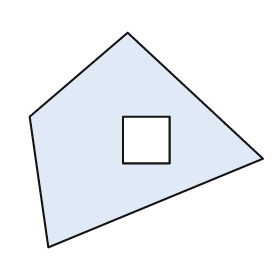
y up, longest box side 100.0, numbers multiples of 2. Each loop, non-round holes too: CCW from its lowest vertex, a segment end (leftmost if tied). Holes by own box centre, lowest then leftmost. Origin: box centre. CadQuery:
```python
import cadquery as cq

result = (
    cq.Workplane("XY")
    .moveTo(-42.0, -46.0)
    .lineTo(50.0, -8.0)
    .lineTo(-8.0, 46.0)
    .lineTo(-50.0, 10.0)
    .close()
    .moveTo(-10.0, -10.0)
    .lineTo(10.0, -10.0)
    .lineTo(10.0, 10.0)
    .lineTo(-10.0, 10.0)
    .close()
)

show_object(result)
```